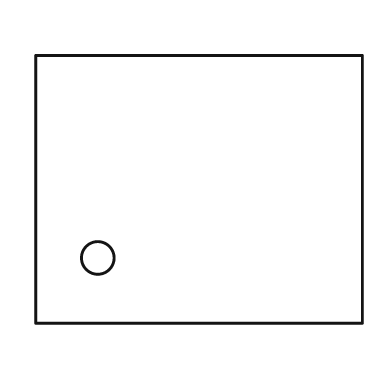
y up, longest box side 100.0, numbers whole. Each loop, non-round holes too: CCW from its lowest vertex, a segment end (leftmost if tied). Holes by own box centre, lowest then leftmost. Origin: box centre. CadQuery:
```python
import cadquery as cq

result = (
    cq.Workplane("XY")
    .moveTo(-50.0, -41.0)
    .lineTo(50.0, -41.0)
    .lineTo(50.0, 41.0)
    .lineTo(-50.0, 41.0)
    .close()
    .moveTo(-31.0, -21.0)
    .circle(5.0)
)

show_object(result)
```